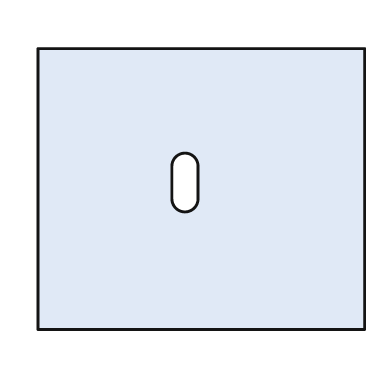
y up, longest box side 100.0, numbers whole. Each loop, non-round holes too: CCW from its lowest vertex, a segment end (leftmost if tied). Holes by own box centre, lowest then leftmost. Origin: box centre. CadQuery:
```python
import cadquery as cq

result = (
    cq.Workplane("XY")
    .moveTo(-50.0, -43.0)
    .lineTo(50.0, -43.0)
    .lineTo(50.0, 43.0)
    .lineTo(-50.0, 43.0)
    .close()
    .moveTo(-9.0, -3.0)
    .threePointArc((-5.0, -7.0), (-1.0, -3.0))
    .lineTo(-1.0, 7.0)
    .threePointArc((-5.0, 11.0), (-9.0, 7.0))
    .close()
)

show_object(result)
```